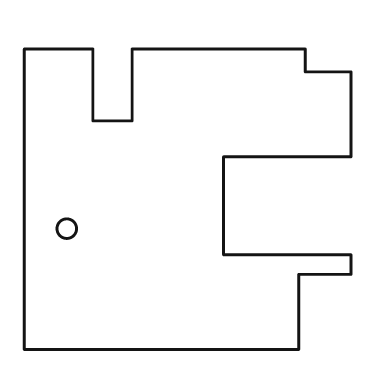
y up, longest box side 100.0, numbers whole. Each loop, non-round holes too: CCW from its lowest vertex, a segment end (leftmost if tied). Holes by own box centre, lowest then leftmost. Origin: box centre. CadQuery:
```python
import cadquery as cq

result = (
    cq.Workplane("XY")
    .moveTo(-50.0, -46.0)
    .lineTo(34.0, -46.0)
    .lineTo(34.0, -23.0)
    .lineTo(50.0, -23.0)
    .lineTo(50.0, -17.0)
    .lineTo(11.0, -17.0)
    .lineTo(11.0, 13.0)
    .lineTo(50.0, 13.0)
    .lineTo(50.0, 39.0)
    .lineTo(36.0, 39.0)
    .lineTo(36.0, 46.0)
    .lineTo(-17.0, 46.0)
    .lineTo(-17.0, 24.0)
    .lineTo(-29.0, 24.0)
    .lineTo(-29.0, 46.0)
    .lineTo(-50.0, 46.0)
    .close()
    .moveTo(-37.0, -9.0)
    .circle(3.0)
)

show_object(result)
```